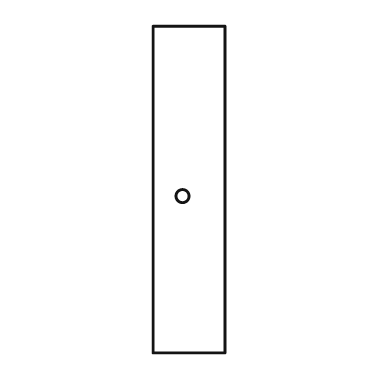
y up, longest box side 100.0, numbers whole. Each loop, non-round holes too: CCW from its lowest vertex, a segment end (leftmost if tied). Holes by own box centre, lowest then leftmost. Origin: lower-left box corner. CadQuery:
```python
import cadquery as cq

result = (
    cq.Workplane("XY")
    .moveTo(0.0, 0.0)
    .lineTo(22.0, 0.0)
    .lineTo(22.0, 100.0)
    .lineTo(0.0, 100.0)
    .close()
    .moveTo(9.0, 48.0)
    .circle(2.0)
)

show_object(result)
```